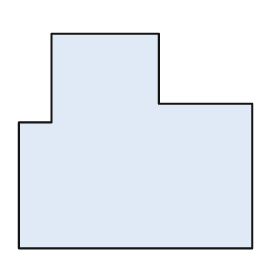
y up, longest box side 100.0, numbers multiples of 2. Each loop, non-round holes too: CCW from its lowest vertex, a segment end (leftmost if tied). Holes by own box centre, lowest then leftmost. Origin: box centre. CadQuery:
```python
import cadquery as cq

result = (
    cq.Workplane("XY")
    .moveTo(-50.0, -46.0)
    .lineTo(50.0, -46.0)
    .lineTo(50.0, 16.0)
    .lineTo(10.0, 16.0)
    .lineTo(10.0, 46.0)
    .lineTo(-36.0, 46.0)
    .lineTo(-36.0, 8.0)
    .lineTo(-50.0, 8.0)
    .close()
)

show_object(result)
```